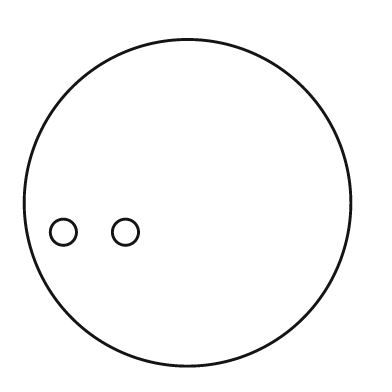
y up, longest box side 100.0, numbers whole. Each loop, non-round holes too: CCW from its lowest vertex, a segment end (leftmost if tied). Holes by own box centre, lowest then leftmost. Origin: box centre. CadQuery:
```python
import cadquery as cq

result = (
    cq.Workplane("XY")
    .moveTo(0.0, 0.0)
    .circle(50.0)
    .moveTo(-38.0, -9.0)
    .circle(4.0)
    .moveTo(-19.0, -9.0)
    .circle(4.0)
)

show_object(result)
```